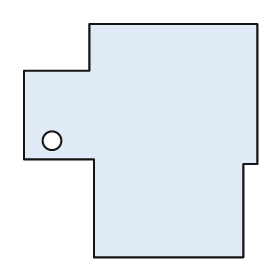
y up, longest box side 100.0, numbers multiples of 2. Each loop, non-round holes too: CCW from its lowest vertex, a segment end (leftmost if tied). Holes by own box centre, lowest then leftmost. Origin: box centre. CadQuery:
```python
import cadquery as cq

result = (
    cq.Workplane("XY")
    .moveTo(-20.0, -50.0)
    .lineTo(44.0, -50.0)
    .lineTo(44.0, -10.0)
    .lineTo(50.0, -10.0)
    .lineTo(50.0, 50.0)
    .lineTo(-22.0, 50.0)
    .lineTo(-22.0, 30.0)
    .lineTo(-50.0, 30.0)
    .lineTo(-50.0, -8.0)
    .lineTo(-20.0, -8.0)
    .close()
    .moveTo(-38.0, 0.0)
    .circle(4.0)
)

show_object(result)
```